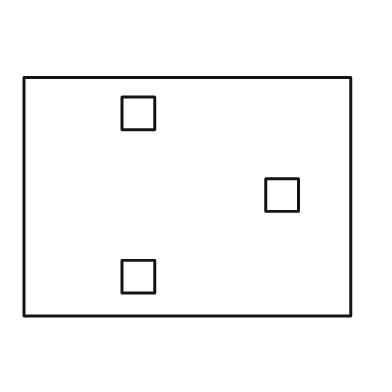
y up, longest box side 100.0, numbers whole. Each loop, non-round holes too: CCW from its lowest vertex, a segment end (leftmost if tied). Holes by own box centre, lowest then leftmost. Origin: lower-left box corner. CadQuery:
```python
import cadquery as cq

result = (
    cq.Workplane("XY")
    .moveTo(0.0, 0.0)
    .lineTo(100.0, 0.0)
    .lineTo(100.0, 73.0)
    .lineTo(0.0, 73.0)
    .close()
    .moveTo(30.0, 7.0)
    .lineTo(40.0, 7.0)
    .lineTo(40.0, 17.0)
    .lineTo(30.0, 17.0)
    .close()
    .moveTo(74.0, 32.0)
    .lineTo(84.0, 32.0)
    .lineTo(84.0, 42.0)
    .lineTo(74.0, 42.0)
    .close()
    .moveTo(30.0, 57.0)
    .lineTo(40.0, 57.0)
    .lineTo(40.0, 67.0)
    .lineTo(30.0, 67.0)
    .close()
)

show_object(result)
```